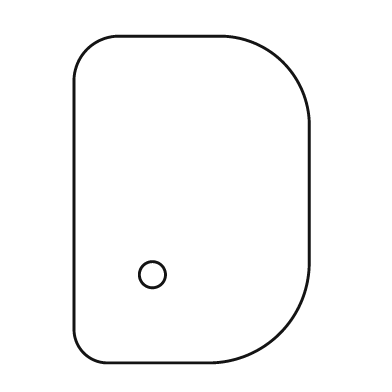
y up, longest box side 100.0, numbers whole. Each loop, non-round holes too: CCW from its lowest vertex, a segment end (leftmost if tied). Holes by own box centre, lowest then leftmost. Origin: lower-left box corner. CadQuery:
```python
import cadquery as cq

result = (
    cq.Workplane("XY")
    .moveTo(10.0, 0.0)
    .lineTo(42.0, 0.0)
    .threePointArc((63.0, 9.0), (72.0, 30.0))
    .lineTo(72.0, 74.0)
    .threePointArc((64.0, 92.0), (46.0, 100.0))
    .lineTo(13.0, 100.0)
    .threePointArc((4.0, 96.0), (0.0, 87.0))
    .lineTo(0.0, 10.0)
    .threePointArc((3.0, 3.0), (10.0, 0.0))
    .close()
    .moveTo(24.0, 27.0)
    .circle(4.0)
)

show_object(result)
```